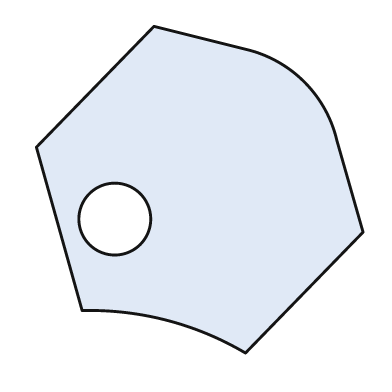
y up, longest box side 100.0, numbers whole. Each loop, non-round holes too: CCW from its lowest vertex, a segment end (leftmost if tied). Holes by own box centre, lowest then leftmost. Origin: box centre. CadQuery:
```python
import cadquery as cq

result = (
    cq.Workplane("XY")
    .moveTo(14.0, -50.0)
    .lineTo(50.0, -13.0)
    .lineTo(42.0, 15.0)
    .threePointArc((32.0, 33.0), (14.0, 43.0))
    .lineTo(-14.0, 50.0)
    .lineTo(-50.0, 13.0)
    .lineTo(-36.0, -37.0)
    .threePointArc((-10.0, -40.0), (14.0, -50.0))
    .close()
    .moveTo(-26.0, -9.0)
    .circle(11.0)
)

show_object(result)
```